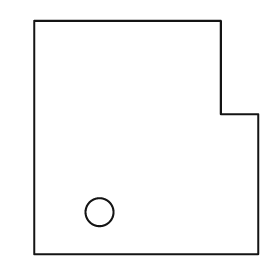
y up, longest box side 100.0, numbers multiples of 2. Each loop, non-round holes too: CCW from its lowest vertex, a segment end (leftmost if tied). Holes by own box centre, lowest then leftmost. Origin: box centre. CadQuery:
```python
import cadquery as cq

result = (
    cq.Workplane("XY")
    .moveTo(-48.0, -50.0)
    .lineTo(48.0, -50.0)
    .lineTo(48.0, 10.0)
    .lineTo(32.0, 10.0)
    .lineTo(32.0, 50.0)
    .lineTo(-48.0, 50.0)
    .close()
    .moveTo(-20.0, -32.0)
    .circle(6.0)
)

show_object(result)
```